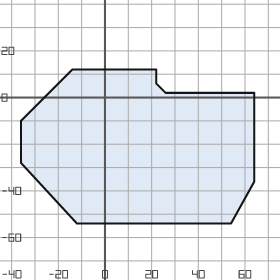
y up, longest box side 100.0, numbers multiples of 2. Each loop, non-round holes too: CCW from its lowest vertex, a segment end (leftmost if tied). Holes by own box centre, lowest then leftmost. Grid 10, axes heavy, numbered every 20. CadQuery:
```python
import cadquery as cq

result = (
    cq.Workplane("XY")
    .moveTo(-12.0, -54.0)
    .lineTo(54.0, -54.0)
    .lineTo(64.0, -36.0)
    .lineTo(64.0, 2.0)
    .lineTo(26.0, 2.0)
    .lineTo(22.0, 6.0)
    .lineTo(22.0, 12.0)
    .lineTo(-14.0, 12.0)
    .lineTo(-36.0, -10.0)
    .lineTo(-36.0, -28.0)
    .close()
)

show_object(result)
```